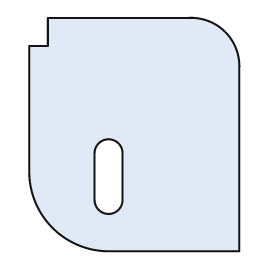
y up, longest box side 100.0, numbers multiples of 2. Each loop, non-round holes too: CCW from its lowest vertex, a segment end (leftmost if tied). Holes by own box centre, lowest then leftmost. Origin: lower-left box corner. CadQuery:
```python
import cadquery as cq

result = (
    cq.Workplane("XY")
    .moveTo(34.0, 0.0)
    .lineTo(90.0, 0.0)
    .lineTo(90.0, 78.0)
    .threePointArc((84.0, 94.0), (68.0, 100.0))
    .lineTo(8.0, 100.0)
    .lineTo(8.0, 88.0)
    .lineTo(0.0, 88.0)
    .lineTo(0.0, 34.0)
    .threePointArc((10.0, 10.0), (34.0, 0.0))
    .close()
    .moveTo(28.0, 22.0)
    .threePointArc((34.0, 16.0), (40.0, 22.0))
    .lineTo(40.0, 42.0)
    .threePointArc((34.0, 48.0), (28.0, 42.0))
    .close()
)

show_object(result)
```